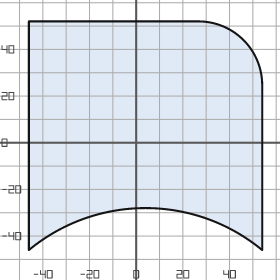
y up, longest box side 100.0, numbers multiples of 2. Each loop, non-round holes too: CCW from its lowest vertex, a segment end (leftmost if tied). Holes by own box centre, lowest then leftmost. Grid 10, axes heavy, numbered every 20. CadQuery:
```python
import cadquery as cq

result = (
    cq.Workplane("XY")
    .moveTo(-46.0, -46.0)
    .threePointArc((4.0, -28.0), (54.0, -46.0))
    .lineTo(54.0, 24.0)
    .threePointArc((46.0, 44.0), (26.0, 52.0))
    .lineTo(-46.0, 52.0)
    .close()
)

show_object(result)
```